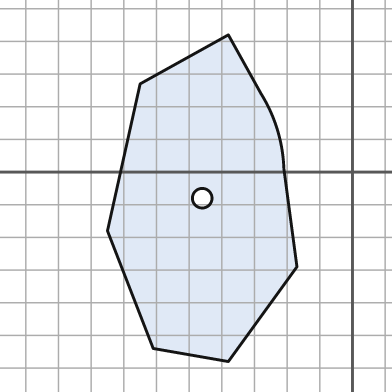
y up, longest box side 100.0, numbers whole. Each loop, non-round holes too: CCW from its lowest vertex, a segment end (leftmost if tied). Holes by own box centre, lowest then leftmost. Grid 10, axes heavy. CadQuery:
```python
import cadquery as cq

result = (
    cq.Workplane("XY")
    .moveTo(-38.0, -58.0)
    .lineTo(-17.0, -29.0)
    .lineTo(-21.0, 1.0)
    .threePointArc((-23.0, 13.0), (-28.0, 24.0))
    .lineTo(-38.0, 42.0)
    .lineTo(-65.0, 27.0)
    .lineTo(-75.0, -18.0)
    .lineTo(-61.0, -54.0)
    .close()
    .moveTo(-46.0, -8.0)
    .circle(3.0)
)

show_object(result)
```